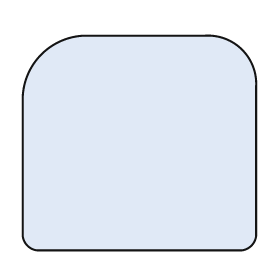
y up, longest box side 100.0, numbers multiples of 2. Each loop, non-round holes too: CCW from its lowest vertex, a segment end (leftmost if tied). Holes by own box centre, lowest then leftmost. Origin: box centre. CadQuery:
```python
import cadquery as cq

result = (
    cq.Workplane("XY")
    .moveTo(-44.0, -46.0)
    .lineTo(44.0, -46.0)
    .threePointArc((48.0, -44.0), (50.0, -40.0))
    .lineTo(50.0, 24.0)
    .threePointArc((44.0, 40.0), (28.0, 46.0))
    .lineTo(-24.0, 46.0)
    .threePointArc((-42.0, 38.0), (-50.0, 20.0))
    .lineTo(-50.0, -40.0)
    .threePointArc((-48.0, -44.0), (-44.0, -46.0))
    .close()
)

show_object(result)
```